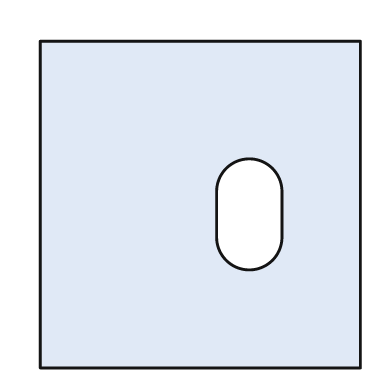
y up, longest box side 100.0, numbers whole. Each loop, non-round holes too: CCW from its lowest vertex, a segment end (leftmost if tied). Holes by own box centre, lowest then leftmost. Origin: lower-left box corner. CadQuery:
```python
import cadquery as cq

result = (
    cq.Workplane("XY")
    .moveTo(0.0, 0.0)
    .lineTo(98.0, 0.0)
    .lineTo(98.0, 100.0)
    .lineTo(0.0, 100.0)
    .close()
    .moveTo(54.0, 40.0)
    .threePointArc((64.0, 30.0), (74.0, 40.0))
    .lineTo(74.0, 54.0)
    .threePointArc((64.0, 64.0), (54.0, 54.0))
    .close()
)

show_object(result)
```